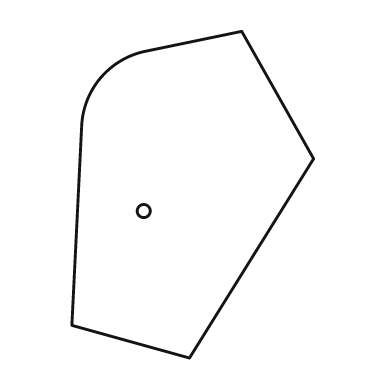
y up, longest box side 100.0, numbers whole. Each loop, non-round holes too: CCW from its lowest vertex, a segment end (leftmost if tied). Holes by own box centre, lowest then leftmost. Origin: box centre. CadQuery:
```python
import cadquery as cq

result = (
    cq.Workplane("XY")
    .moveTo(-1.0, -50.0)
    .lineTo(37.0, 11.0)
    .lineTo(15.0, 50.0)
    .lineTo(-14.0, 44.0)
    .threePointArc((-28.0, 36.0), (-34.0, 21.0))
    .lineTo(-37.0, -40.0)
    .close()
    .moveTo(-15.0, -5.0)
    .circle(2.0)
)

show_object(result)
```